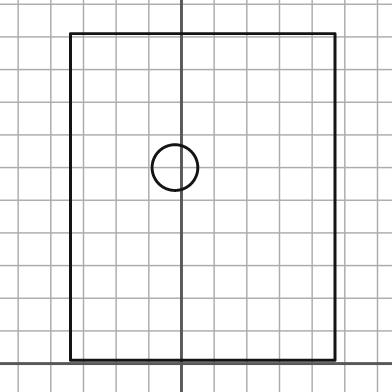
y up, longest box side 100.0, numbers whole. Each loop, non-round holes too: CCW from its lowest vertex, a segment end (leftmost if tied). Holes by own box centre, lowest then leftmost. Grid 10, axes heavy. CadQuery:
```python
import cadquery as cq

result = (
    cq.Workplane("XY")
    .moveTo(-34.0, 1.0)
    .lineTo(47.0, 1.0)
    .lineTo(47.0, 101.0)
    .lineTo(-34.0, 101.0)
    .close()
    .moveTo(-2.0, 60.0)
    .circle(7.0)
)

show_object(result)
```